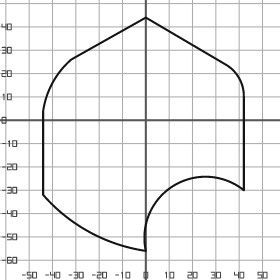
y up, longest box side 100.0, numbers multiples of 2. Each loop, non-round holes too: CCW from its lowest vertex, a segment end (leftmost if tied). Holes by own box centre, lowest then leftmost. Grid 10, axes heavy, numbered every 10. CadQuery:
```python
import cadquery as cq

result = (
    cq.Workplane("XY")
    .moveTo(0.0, -56.0)
    .threePointArc((12.0, -28.0), (42.0, -30.0))
    .lineTo(42.0, 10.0)
    .threePointArc((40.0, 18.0), (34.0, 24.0))
    .lineTo(0.0, 44.0)
    .lineTo(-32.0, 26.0)
    .threePointArc((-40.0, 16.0), (-44.0, 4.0))
    .lineTo(-44.0, -32.0)
    .threePointArc((-24.0, -48.0), (0.0, -56.0))
    .close()
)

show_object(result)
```